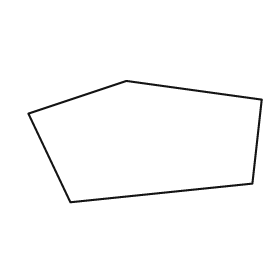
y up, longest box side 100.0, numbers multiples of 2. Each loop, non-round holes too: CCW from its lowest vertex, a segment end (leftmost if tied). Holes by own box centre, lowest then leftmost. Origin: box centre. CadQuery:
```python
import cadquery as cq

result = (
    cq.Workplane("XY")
    .moveTo(-32.0, -26.0)
    .lineTo(46.0, -18.0)
    .lineTo(50.0, 18.0)
    .lineTo(-8.0, 26.0)
    .lineTo(-50.0, 12.0)
    .close()
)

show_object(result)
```